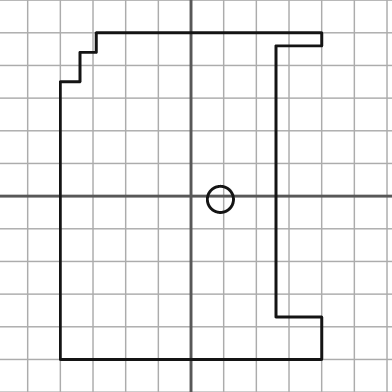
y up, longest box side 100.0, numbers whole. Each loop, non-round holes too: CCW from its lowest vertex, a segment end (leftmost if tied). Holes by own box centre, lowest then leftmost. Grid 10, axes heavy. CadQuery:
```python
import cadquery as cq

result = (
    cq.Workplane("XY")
    .moveTo(-40.0, -50.0)
    .lineTo(40.0, -50.0)
    .lineTo(40.0, -37.0)
    .lineTo(26.0, -37.0)
    .lineTo(26.0, 46.0)
    .lineTo(40.0, 46.0)
    .lineTo(40.0, 50.0)
    .lineTo(-29.0, 50.0)
    .lineTo(-29.0, 44.0)
    .lineTo(-34.0, 44.0)
    .lineTo(-34.0, 35.0)
    .lineTo(-40.0, 35.0)
    .close()
    .moveTo(9.0, -1.0)
    .circle(4.0)
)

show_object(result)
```